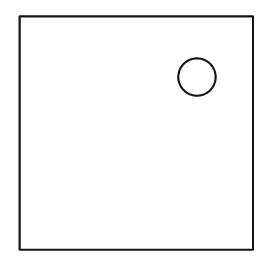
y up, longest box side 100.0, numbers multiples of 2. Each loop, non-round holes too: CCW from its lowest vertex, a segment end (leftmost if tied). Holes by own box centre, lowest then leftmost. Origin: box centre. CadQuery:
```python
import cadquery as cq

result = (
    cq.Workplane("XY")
    .moveTo(-50.0, -50.0)
    .lineTo(50.0, -50.0)
    .lineTo(50.0, 50.0)
    .lineTo(-50.0, 50.0)
    .close()
    .moveTo(26.0, 24.0)
    .circle(8.0)
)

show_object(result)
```